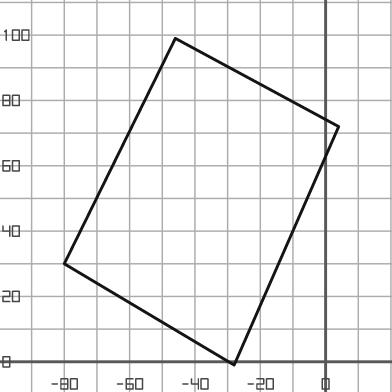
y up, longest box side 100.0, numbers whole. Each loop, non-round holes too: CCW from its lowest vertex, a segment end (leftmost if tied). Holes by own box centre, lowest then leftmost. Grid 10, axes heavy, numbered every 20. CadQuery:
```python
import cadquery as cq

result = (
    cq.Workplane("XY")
    .moveTo(-28.0, -1.0)
    .lineTo(4.0, 72.0)
    .lineTo(-46.0, 99.0)
    .lineTo(-80.0, 30.0)
    .close()
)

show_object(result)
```